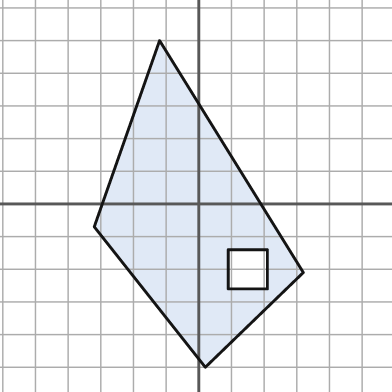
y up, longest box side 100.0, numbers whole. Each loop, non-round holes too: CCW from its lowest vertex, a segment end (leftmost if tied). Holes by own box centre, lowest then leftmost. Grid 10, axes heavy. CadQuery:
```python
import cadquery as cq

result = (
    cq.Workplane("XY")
    .moveTo(2.0, -50.0)
    .lineTo(32.0, -21.0)
    .lineTo(-12.0, 50.0)
    .lineTo(-32.0, -7.0)
    .close()
    .moveTo(9.0, -26.0)
    .lineTo(21.0, -26.0)
    .lineTo(21.0, -14.0)
    .lineTo(9.0, -14.0)
    .close()
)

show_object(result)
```